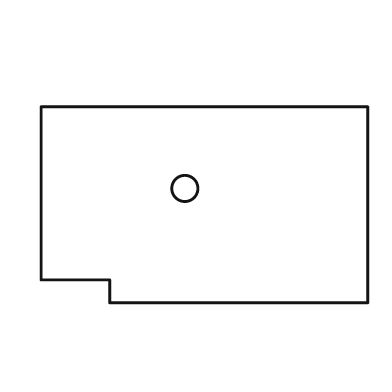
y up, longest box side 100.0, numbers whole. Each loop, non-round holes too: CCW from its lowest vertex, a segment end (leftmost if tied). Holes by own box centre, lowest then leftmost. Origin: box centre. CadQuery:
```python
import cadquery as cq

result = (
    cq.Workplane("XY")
    .moveTo(-29.0, -30.0)
    .lineTo(50.0, -30.0)
    .lineTo(50.0, 30.0)
    .lineTo(-50.0, 30.0)
    .lineTo(-50.0, -23.0)
    .lineTo(-29.0, -23.0)
    .close()
    .moveTo(-6.0, 5.0)
    .circle(4.0)
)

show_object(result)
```